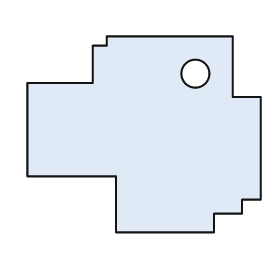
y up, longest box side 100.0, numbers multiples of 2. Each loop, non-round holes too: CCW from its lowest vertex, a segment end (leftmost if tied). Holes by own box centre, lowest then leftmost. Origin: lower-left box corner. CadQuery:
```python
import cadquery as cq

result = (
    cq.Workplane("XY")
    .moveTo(38.0, 0.0)
    .lineTo(80.0, 0.0)
    .lineTo(80.0, 8.0)
    .lineTo(92.0, 8.0)
    .lineTo(92.0, 14.0)
    .lineTo(100.0, 14.0)
    .lineTo(100.0, 58.0)
    .lineTo(88.0, 58.0)
    .lineTo(88.0, 84.0)
    .lineTo(34.0, 84.0)
    .lineTo(34.0, 80.0)
    .lineTo(28.0, 80.0)
    .lineTo(28.0, 64.0)
    .lineTo(0.0, 64.0)
    .lineTo(0.0, 24.0)
    .lineTo(38.0, 24.0)
    .close()
    .moveTo(72.0, 68.0)
    .circle(6.0)
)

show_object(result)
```